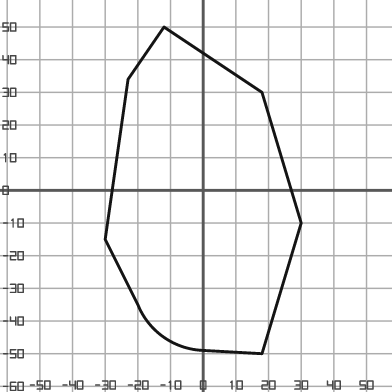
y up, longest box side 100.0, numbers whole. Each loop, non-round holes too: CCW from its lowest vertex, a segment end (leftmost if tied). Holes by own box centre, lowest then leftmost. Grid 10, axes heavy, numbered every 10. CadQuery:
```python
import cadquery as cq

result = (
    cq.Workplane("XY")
    .moveTo(18.0, -50.0)
    .lineTo(30.0, -10.0)
    .lineTo(18.0, 30.0)
    .lineTo(-12.0, 50.0)
    .lineTo(-23.0, 34.0)
    .lineTo(-30.0, -15.0)
    .lineTo(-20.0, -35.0)
    .threePointArc((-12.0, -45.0), (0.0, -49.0))
    .close()
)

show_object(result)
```